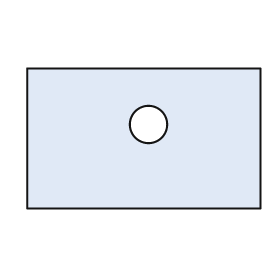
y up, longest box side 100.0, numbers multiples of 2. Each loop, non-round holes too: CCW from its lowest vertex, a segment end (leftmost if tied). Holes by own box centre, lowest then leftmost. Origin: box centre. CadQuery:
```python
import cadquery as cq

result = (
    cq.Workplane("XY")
    .moveTo(-50.0, -30.0)
    .lineTo(50.0, -30.0)
    .lineTo(50.0, 30.0)
    .lineTo(-50.0, 30.0)
    .close()
    .moveTo(2.0, 6.0)
    .circle(8.0)
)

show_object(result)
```